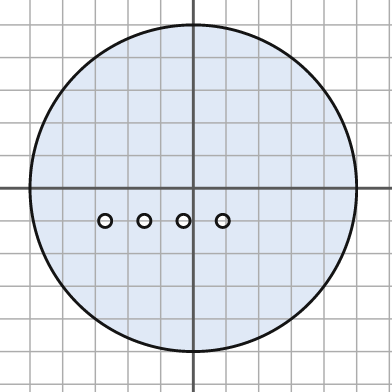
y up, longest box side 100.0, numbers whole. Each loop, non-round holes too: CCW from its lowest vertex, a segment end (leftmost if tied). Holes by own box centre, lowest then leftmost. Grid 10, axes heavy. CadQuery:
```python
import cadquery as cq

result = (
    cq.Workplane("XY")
    .moveTo(0.0, 0.0)
    .circle(50.0)
    .moveTo(-27.0, -10.0)
    .circle(2.0)
    .moveTo(-15.0, -10.0)
    .circle(2.0)
    .moveTo(-3.0, -10.0)
    .circle(2.0)
    .moveTo(9.0, -10.0)
    .circle(2.0)
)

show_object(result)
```